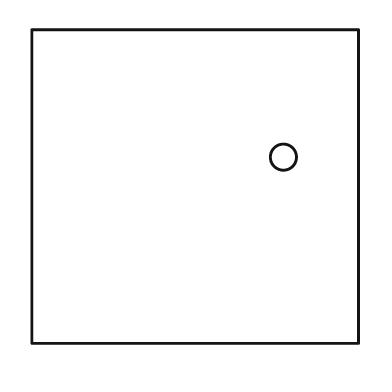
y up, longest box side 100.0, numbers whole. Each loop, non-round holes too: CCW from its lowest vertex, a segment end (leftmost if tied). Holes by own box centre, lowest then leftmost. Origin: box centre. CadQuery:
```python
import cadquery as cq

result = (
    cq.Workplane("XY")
    .moveTo(-50.0, -48.0)
    .lineTo(50.0, -48.0)
    .lineTo(50.0, 48.0)
    .lineTo(-50.0, 48.0)
    .close()
    .moveTo(27.0, 9.0)
    .circle(4.0)
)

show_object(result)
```